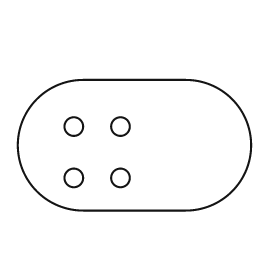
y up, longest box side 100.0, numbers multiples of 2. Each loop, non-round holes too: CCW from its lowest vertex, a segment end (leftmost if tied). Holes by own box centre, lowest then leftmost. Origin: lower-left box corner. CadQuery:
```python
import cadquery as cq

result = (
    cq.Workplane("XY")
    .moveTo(28.0, 0.0)
    .lineTo(72.0, 0.0)
    .threePointArc((100.0, 28.0), (72.0, 56.0))
    .lineTo(28.0, 56.0)
    .threePointArc((0.0, 28.0), (28.0, 0.0))
    .close()
    .moveTo(24.0, 14.0)
    .circle(4.0)
    .moveTo(44.0, 14.0)
    .circle(4.0)
    .moveTo(24.0, 36.0)
    .circle(4.0)
    .moveTo(44.0, 36.0)
    .circle(4.0)
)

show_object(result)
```